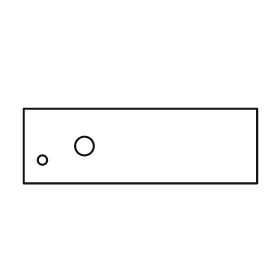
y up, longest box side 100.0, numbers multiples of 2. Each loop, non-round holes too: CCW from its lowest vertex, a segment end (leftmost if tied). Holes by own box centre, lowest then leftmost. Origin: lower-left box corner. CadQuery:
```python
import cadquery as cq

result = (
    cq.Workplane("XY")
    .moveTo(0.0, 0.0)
    .lineTo(100.0, 0.0)
    .lineTo(100.0, 32.0)
    .lineTo(0.0, 32.0)
    .close()
    .moveTo(8.0, 10.0)
    .circle(2.0)
    .moveTo(26.0, 16.0)
    .circle(4.0)
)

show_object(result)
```